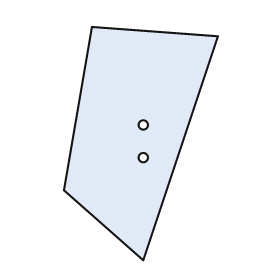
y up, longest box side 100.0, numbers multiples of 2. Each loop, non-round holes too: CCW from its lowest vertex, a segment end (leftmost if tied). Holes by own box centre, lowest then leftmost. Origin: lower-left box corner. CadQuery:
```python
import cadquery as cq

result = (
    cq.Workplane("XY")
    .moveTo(34.0, 0.0)
    .lineTo(66.0, 96.0)
    .lineTo(12.0, 100.0)
    .lineTo(0.0, 30.0)
    .close()
    .moveTo(34.0, 44.0)
    .circle(2.0)
    .moveTo(34.0, 58.0)
    .circle(2.0)
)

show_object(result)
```